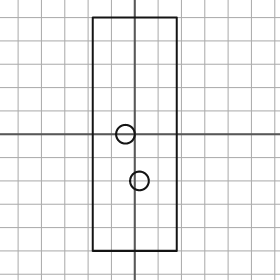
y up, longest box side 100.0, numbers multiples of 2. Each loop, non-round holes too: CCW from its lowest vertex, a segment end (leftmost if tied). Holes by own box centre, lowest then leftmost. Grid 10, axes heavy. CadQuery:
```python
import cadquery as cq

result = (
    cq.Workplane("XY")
    .moveTo(-18.0, -50.0)
    .lineTo(18.0, -50.0)
    .lineTo(18.0, 50.0)
    .lineTo(-18.0, 50.0)
    .close()
    .moveTo(2.0, -20.0)
    .circle(4.0)
    .moveTo(-4.0, 0.0)
    .circle(4.0)
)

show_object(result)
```